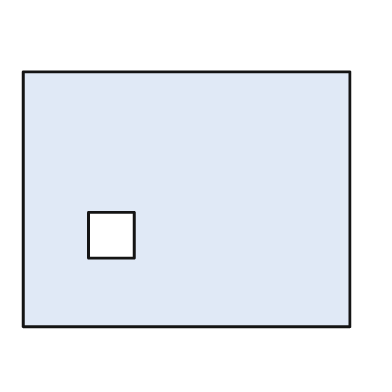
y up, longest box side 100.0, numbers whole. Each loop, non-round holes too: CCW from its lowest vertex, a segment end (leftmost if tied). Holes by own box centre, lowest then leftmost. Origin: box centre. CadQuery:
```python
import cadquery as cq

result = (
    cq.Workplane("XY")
    .moveTo(-50.0, -39.0)
    .lineTo(50.0, -39.0)
    .lineTo(50.0, 39.0)
    .lineTo(-50.0, 39.0)
    .close()
    .moveTo(-30.0, -18.0)
    .lineTo(-16.0, -18.0)
    .lineTo(-16.0, -4.0)
    .lineTo(-30.0, -4.0)
    .close()
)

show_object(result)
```